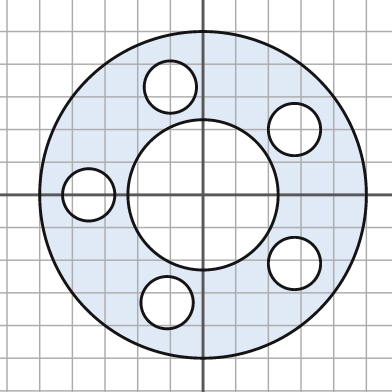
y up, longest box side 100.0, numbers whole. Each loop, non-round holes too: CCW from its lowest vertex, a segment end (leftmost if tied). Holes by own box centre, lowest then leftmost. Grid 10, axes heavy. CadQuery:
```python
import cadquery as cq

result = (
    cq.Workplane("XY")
    .moveTo(0.0, 0.0)
    .circle(50.0)
    .moveTo(-11.0, -33.0)
    .circle(8.0)
    .moveTo(28.0, -21.0)
    .circle(8.0)
    .moveTo(-35.0, 0.0)
    .circle(8.0)
    .moveTo(0.0, 0.0)
    .circle(23.0)
    .moveTo(28.0, 20.0)
    .circle(8.0)
    .moveTo(-10.0, 33.0)
    .circle(8.0)
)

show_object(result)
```